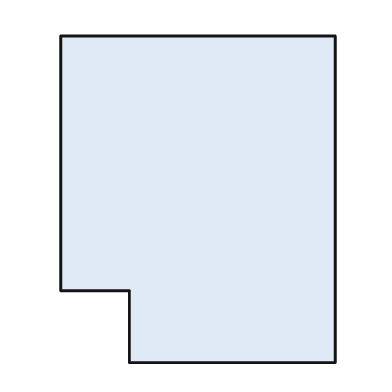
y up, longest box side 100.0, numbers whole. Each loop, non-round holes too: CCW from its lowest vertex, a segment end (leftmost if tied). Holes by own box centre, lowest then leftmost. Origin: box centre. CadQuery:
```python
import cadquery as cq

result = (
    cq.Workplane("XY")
    .moveTo(-21.0, -50.0)
    .lineTo(42.0, -50.0)
    .lineTo(42.0, 50.0)
    .lineTo(-42.0, 50.0)
    .lineTo(-42.0, -28.0)
    .lineTo(-21.0, -28.0)
    .close()
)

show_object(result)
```